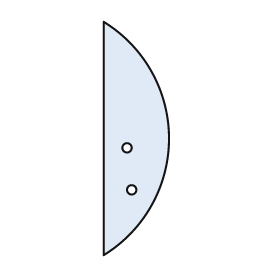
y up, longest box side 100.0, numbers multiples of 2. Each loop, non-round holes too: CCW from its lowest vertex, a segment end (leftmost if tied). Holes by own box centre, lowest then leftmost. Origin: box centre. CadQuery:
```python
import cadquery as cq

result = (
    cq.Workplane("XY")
    .moveTo(-14.0, -50.0)
    .threePointArc((14.0, 0.0), (-14.0, 50.0))
    .close()
    .moveTo(-2.0, -22.0)
    .circle(2.0)
    .moveTo(-4.0, -4.0)
    .circle(2.0)
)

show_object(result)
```